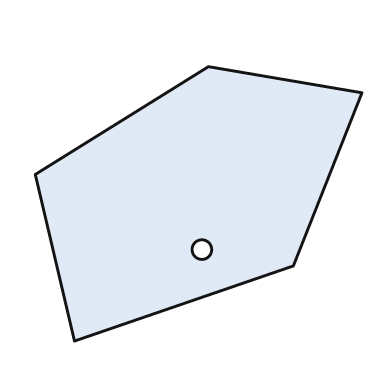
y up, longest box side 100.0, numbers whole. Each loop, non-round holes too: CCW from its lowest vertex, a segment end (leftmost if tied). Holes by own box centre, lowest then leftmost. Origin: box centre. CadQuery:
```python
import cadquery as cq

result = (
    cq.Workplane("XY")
    .moveTo(-38.0, -42.0)
    .lineTo(29.0, -19.0)
    .lineTo(50.0, 34.0)
    .lineTo(3.0, 42.0)
    .lineTo(-50.0, 9.0)
    .close()
    .moveTo(1.0, -14.0)
    .circle(3.0)
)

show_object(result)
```